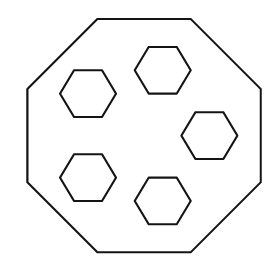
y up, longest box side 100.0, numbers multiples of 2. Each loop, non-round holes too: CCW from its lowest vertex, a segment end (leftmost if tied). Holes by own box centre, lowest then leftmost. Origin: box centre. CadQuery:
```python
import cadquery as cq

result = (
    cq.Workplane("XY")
    .moveTo(-20.0, -50.0)
    .lineTo(20.0, -50.0)
    .lineTo(50.0, -20.0)
    .lineTo(50.0, 20.0)
    .lineTo(20.0, 50.0)
    .lineTo(-20.0, 50.0)
    .lineTo(-50.0, 20.0)
    .lineTo(-50.0, -20.0)
    .close()
    .moveTo(2.0, -38.0)
    .lineTo(14.0, -38.0)
    .lineTo(20.0, -28.0)
    .lineTo(14.0, -18.0)
    .lineTo(2.0, -18.0)
    .lineTo(-4.0, -28.0)
    .close()
    .moveTo(-30.0, -28.0)
    .lineTo(-18.0, -28.0)
    .lineTo(-12.0, -18.0)
    .lineTo(-18.0, -8.0)
    .lineTo(-30.0, -8.0)
    .lineTo(-36.0, -18.0)
    .close()
    .moveTo(22.0, -10.0)
    .lineTo(34.0, -10.0)
    .lineTo(40.0, 0.0)
    .lineTo(34.0, 10.0)
    .lineTo(22.0, 10.0)
    .lineTo(16.0, 0.0)
    .close()
    .moveTo(-30.0, 8.0)
    .lineTo(-18.0, 8.0)
    .lineTo(-12.0, 18.0)
    .lineTo(-18.0, 28.0)
    .lineTo(-30.0, 28.0)
    .lineTo(-36.0, 18.0)
    .close()
    .moveTo(2.0, 18.0)
    .lineTo(14.0, 18.0)
    .lineTo(20.0, 28.0)
    .lineTo(14.0, 38.0)
    .lineTo(2.0, 38.0)
    .lineTo(-4.0, 28.0)
    .close()
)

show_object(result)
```